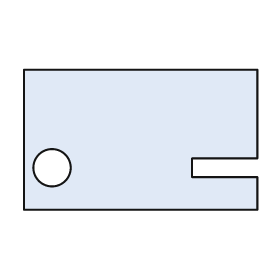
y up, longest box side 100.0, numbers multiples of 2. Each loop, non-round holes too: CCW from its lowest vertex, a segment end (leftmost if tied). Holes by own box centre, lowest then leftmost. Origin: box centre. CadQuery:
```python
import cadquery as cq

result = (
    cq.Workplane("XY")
    .moveTo(-50.0, -30.0)
    .lineTo(50.0, -30.0)
    .lineTo(50.0, -16.0)
    .lineTo(22.0, -16.0)
    .lineTo(22.0, -8.0)
    .lineTo(50.0, -8.0)
    .lineTo(50.0, 30.0)
    .lineTo(-50.0, 30.0)
    .close()
    .moveTo(-38.0, -12.0)
    .circle(8.0)
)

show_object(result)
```